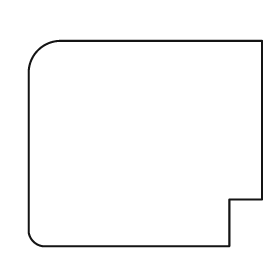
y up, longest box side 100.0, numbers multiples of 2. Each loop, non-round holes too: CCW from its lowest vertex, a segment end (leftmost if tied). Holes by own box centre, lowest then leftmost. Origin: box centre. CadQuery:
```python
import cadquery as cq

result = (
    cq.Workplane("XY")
    .moveTo(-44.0, -44.0)
    .lineTo(36.0, -44.0)
    .lineTo(36.0, -24.0)
    .lineTo(50.0, -24.0)
    .lineTo(50.0, 44.0)
    .lineTo(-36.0, 44.0)
    .threePointArc((-46.0, 40.0), (-50.0, 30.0))
    .lineTo(-50.0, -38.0)
    .threePointArc((-48.0, -42.0), (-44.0, -44.0))
    .close()
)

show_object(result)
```